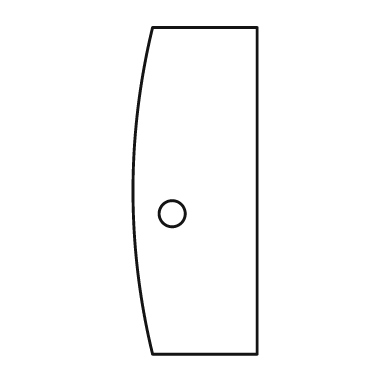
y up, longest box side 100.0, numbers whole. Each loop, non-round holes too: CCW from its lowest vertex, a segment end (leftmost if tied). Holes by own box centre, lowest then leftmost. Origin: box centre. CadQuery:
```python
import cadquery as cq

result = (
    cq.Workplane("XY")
    .moveTo(-13.0, -50.0)
    .lineTo(19.0, -50.0)
    .lineTo(19.0, 50.0)
    .lineTo(-13.0, 50.0)
    .threePointArc((-19.0, 0.0), (-13.0, -50.0))
    .close()
    .moveTo(-7.0, -7.0)
    .circle(4.0)
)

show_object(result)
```